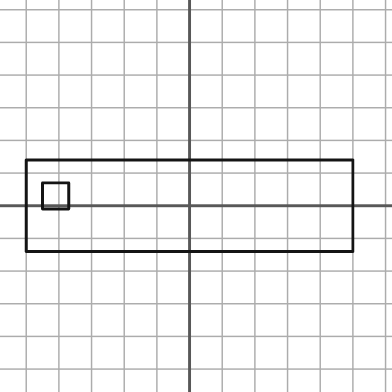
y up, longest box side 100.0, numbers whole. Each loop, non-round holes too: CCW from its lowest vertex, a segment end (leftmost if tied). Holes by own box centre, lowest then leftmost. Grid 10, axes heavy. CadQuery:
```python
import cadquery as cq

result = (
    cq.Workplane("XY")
    .moveTo(-50.0, -14.0)
    .lineTo(50.0, -14.0)
    .lineTo(50.0, 14.0)
    .lineTo(-50.0, 14.0)
    .close()
    .moveTo(-45.0, -1.0)
    .lineTo(-37.0, -1.0)
    .lineTo(-37.0, 7.0)
    .lineTo(-45.0, 7.0)
    .close()
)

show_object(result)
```